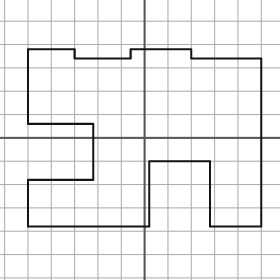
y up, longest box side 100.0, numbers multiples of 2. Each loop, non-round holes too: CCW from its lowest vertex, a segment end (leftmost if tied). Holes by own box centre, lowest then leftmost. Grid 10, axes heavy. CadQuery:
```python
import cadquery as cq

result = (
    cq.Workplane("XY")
    .moveTo(-50.0, -38.0)
    .lineTo(2.0, -38.0)
    .lineTo(2.0, -10.0)
    .lineTo(28.0, -10.0)
    .lineTo(28.0, -38.0)
    .lineTo(50.0, -38.0)
    .lineTo(50.0, 34.0)
    .lineTo(20.0, 34.0)
    .lineTo(20.0, 38.0)
    .lineTo(-6.0, 38.0)
    .lineTo(-6.0, 34.0)
    .lineTo(-30.0, 34.0)
    .lineTo(-30.0, 38.0)
    .lineTo(-50.0, 38.0)
    .lineTo(-50.0, 6.0)
    .lineTo(-22.0, 6.0)
    .lineTo(-22.0, -18.0)
    .lineTo(-50.0, -18.0)
    .close()
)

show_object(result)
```